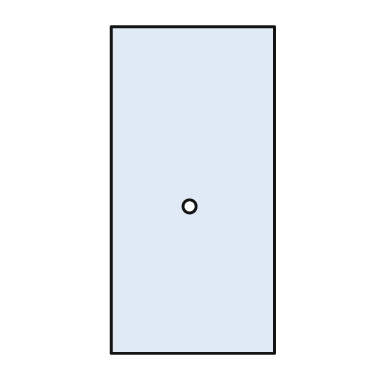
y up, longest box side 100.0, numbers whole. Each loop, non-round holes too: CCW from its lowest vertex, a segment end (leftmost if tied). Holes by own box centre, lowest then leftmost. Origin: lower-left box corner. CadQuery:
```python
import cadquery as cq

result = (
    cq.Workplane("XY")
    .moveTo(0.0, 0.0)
    .lineTo(50.0, 0.0)
    .lineTo(50.0, 100.0)
    .lineTo(0.0, 100.0)
    .close()
    .moveTo(24.0, 45.0)
    .circle(2.0)
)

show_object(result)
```